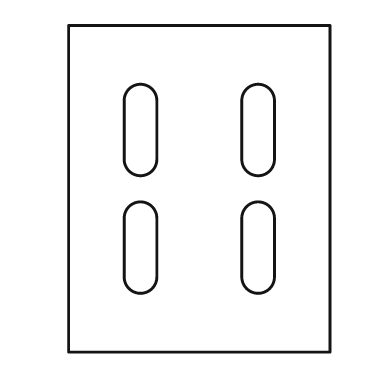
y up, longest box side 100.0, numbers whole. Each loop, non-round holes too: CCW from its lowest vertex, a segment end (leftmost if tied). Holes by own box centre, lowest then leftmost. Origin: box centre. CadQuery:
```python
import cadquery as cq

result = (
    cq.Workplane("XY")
    .moveTo(-40.0, -50.0)
    .lineTo(40.0, -50.0)
    .lineTo(40.0, 50.0)
    .lineTo(-40.0, 50.0)
    .close()
    .moveTo(-23.0, -27.0)
    .threePointArc((-18.0, -32.0), (-13.0, -27.0))
    .lineTo(-13.0, -9.0)
    .threePointArc((-18.0, -4.0), (-23.0, -9.0))
    .close()
    .moveTo(13.0, -27.0)
    .threePointArc((18.0, -32.0), (23.0, -27.0))
    .lineTo(23.0, -9.0)
    .threePointArc((18.0, -4.0), (13.0, -9.0))
    .close()
    .moveTo(-23.0, 9.0)
    .threePointArc((-18.0, 4.0), (-13.0, 9.0))
    .lineTo(-13.0, 27.0)
    .threePointArc((-18.0, 32.0), (-23.0, 27.0))
    .close()
    .moveTo(13.0, 9.0)
    .threePointArc((18.0, 4.0), (23.0, 9.0))
    .lineTo(23.0, 27.0)
    .threePointArc((18.0, 32.0), (13.0, 27.0))
    .close()
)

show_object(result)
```